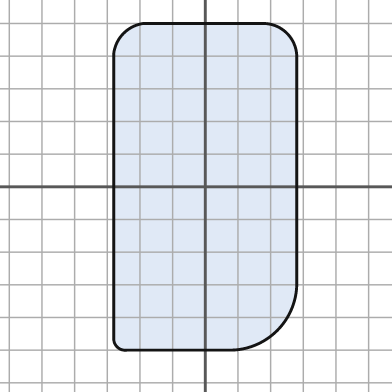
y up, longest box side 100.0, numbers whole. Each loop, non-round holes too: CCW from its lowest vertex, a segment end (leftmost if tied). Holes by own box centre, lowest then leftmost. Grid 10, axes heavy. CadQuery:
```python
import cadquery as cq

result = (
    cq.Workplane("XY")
    .moveTo(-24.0, -50.0)
    .lineTo(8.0, -50.0)
    .threePointArc((22.0, -44.0), (28.0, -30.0))
    .lineTo(28.0, 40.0)
    .threePointArc((25.0, 47.0), (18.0, 50.0))
    .lineTo(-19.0, 50.0)
    .threePointArc((-25.0, 47.0), (-28.0, 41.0))
    .lineTo(-28.0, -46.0)
    .threePointArc((-27.0, -49.0), (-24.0, -50.0))
    .close()
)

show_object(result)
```